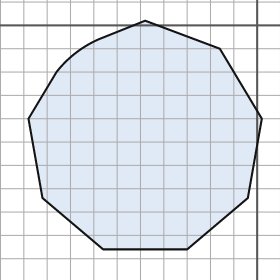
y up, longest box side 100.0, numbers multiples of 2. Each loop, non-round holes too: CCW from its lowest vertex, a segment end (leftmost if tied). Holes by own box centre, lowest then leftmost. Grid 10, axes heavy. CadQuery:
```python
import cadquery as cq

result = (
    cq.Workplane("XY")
    .moveTo(-66.0, -96.0)
    .lineTo(-30.0, -96.0)
    .lineTo(-4.0, -74.0)
    .lineTo(2.0, -40.0)
    .lineTo(-16.0, -10.0)
    .lineTo(-48.0, 2.0)
    .lineTo(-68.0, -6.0)
    .threePointArc((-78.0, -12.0), (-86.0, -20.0))
    .lineTo(-98.0, -40.0)
    .lineTo(-92.0, -74.0)
    .close()
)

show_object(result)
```